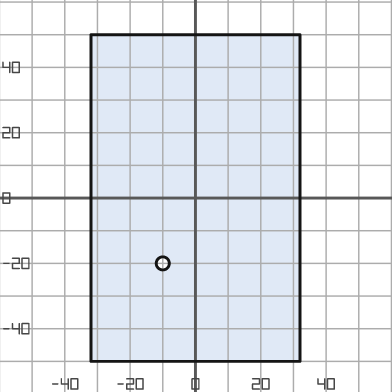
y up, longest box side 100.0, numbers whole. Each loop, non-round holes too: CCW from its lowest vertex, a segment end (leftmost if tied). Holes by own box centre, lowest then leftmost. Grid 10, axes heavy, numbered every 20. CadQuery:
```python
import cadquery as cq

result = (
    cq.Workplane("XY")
    .moveTo(-32.0, -50.0)
    .lineTo(32.0, -50.0)
    .lineTo(32.0, 50.0)
    .lineTo(-32.0, 50.0)
    .close()
    .moveTo(-10.0, -20.0)
    .circle(2.0)
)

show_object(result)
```